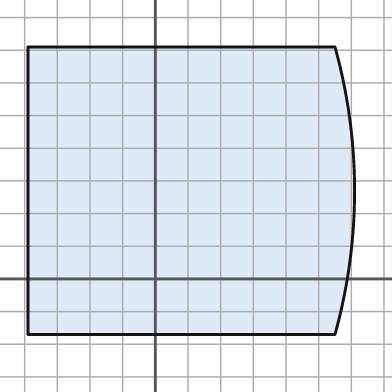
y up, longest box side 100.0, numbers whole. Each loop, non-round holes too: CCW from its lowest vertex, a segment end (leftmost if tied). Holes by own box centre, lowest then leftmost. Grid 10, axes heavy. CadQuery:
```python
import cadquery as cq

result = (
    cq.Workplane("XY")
    .moveTo(-39.0, -17.0)
    .lineTo(55.0, -17.0)
    .threePointArc((61.0, 27.0), (55.0, 71.0))
    .lineTo(-39.0, 71.0)
    .close()
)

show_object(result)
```